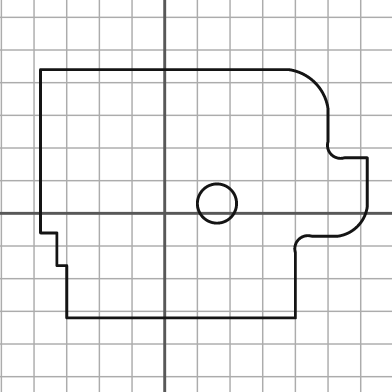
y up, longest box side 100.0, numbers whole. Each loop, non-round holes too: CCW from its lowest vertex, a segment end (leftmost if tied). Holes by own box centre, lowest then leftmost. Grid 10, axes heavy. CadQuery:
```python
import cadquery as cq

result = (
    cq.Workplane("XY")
    .moveTo(-30.0, -32.0)
    .lineTo(40.0, -32.0)
    .lineTo(40.0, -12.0)
    .threePointArc((41.0, -8.0), (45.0, -7.0))
    .lineTo(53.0, -7.0)
    .threePointArc((59.0, -4.0), (62.0, 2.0))
    .lineTo(62.0, 17.0)
    .lineTo(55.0, 17.0)
    .threePointArc((51.0, 18.0), (50.0, 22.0))
    .lineTo(50.0, 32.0)
    .threePointArc((46.0, 40.0), (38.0, 44.0))
    .lineTo(-38.0, 44.0)
    .lineTo(-38.0, -6.0)
    .lineTo(-33.0, -6.0)
    .lineTo(-33.0, -16.0)
    .lineTo(-30.0, -16.0)
    .close()
    .moveTo(16.0, 3.0)
    .circle(6.0)
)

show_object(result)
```